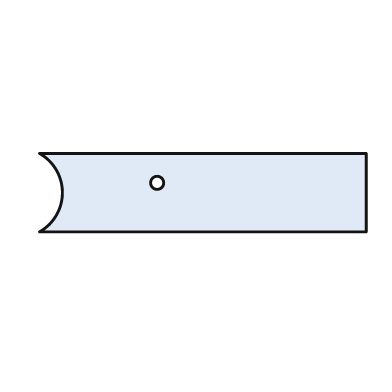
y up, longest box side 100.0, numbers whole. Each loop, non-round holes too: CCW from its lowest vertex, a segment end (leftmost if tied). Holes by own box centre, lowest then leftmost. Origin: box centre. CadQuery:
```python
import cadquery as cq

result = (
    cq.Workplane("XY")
    .moveTo(-50.0, -12.0)
    .lineTo(50.0, -12.0)
    .lineTo(50.0, 12.0)
    .lineTo(-50.0, 12.0)
    .threePointArc((-43.0, 0.0), (-50.0, -12.0))
    .close()
    .moveTo(-14.0, 3.0)
    .circle(2.0)
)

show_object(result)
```